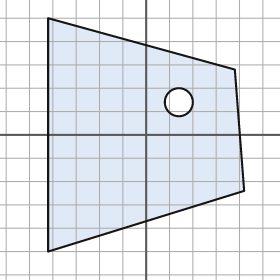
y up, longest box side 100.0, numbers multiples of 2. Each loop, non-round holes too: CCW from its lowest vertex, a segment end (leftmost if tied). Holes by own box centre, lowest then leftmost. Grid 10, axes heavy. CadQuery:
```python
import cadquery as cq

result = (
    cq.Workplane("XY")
    .moveTo(-42.0, -50.0)
    .lineTo(42.0, -24.0)
    .lineTo(38.0, 28.0)
    .lineTo(-42.0, 50.0)
    .close()
    .moveTo(14.0, 14.0)
    .circle(6.0)
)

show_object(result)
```